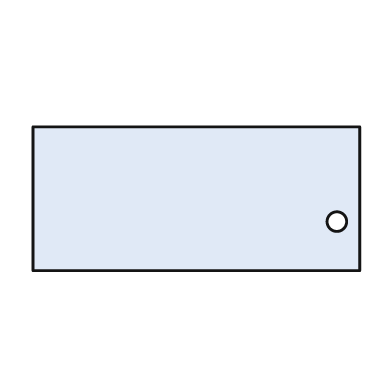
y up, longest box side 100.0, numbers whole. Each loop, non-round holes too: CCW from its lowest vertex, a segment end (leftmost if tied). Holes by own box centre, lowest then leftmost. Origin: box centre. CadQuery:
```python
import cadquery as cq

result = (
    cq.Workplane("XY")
    .moveTo(-50.0, -22.0)
    .lineTo(50.0, -22.0)
    .lineTo(50.0, 22.0)
    .lineTo(-50.0, 22.0)
    .close()
    .moveTo(43.0, -7.0)
    .circle(3.0)
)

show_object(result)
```